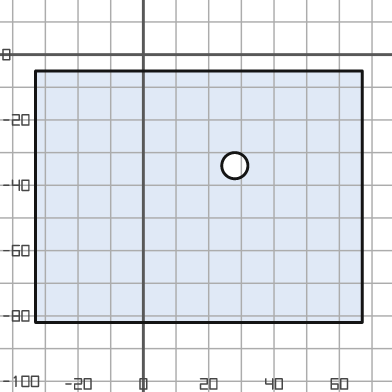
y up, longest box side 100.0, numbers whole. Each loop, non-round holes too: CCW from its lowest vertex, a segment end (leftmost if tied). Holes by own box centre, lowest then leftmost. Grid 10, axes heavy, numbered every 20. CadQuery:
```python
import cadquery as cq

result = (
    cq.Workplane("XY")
    .moveTo(-33.0, -82.0)
    .lineTo(67.0, -82.0)
    .lineTo(67.0, -5.0)
    .lineTo(-33.0, -5.0)
    .close()
    .moveTo(28.0, -34.0)
    .circle(4.0)
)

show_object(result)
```